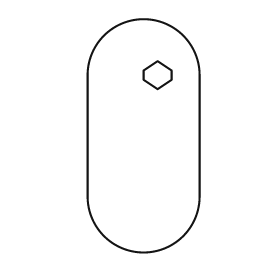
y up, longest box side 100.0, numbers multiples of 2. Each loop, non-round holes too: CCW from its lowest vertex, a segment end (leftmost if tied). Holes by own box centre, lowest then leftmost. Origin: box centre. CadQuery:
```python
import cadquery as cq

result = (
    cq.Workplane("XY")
    .moveTo(-24.0, -26.0)
    .threePointArc((0.0, -50.0), (24.0, -26.0))
    .lineTo(24.0, 26.0)
    .threePointArc((0.0, 50.0), (-24.0, 26.0))
    .close()
    .moveTo(6.0, 20.0)
    .lineTo(12.0, 24.0)
    .lineTo(12.0, 28.0)
    .lineTo(6.0, 32.0)
    .lineTo(0.0, 28.0)
    .lineTo(0.0, 24.0)
    .close()
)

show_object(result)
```